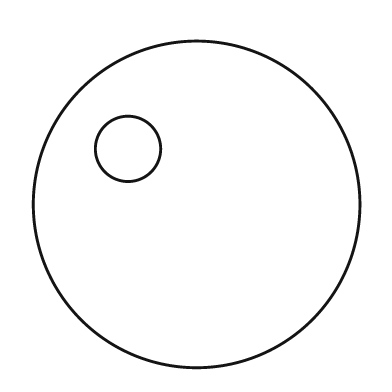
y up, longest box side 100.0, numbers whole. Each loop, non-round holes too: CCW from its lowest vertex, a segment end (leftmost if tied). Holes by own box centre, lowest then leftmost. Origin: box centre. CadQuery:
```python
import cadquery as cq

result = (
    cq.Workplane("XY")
    .moveTo(0.0, 0.0)
    .circle(50.0)
    .moveTo(-21.0, 17.0)
    .circle(10.0)
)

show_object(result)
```